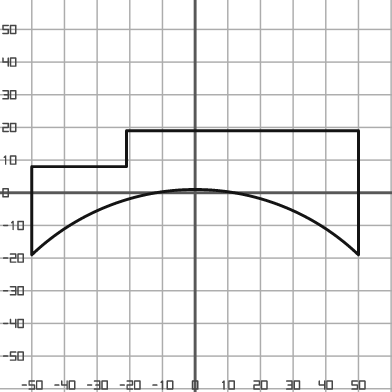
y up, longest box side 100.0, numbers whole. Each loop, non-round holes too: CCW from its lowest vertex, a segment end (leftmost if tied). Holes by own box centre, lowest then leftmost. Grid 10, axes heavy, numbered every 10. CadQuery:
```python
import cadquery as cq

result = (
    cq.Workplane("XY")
    .moveTo(-50.0, -19.0)
    .threePointArc((0.0, 1.0), (50.0, -19.0))
    .lineTo(50.0, 19.0)
    .lineTo(-21.0, 19.0)
    .lineTo(-21.0, 8.0)
    .lineTo(-50.0, 8.0)
    .close()
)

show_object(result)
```